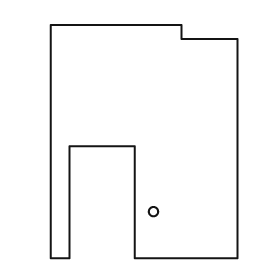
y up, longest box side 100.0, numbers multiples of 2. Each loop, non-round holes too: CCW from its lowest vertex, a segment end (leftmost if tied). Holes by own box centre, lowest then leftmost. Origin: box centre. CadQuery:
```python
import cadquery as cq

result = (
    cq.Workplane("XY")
    .moveTo(-40.0, -50.0)
    .lineTo(-32.0, -50.0)
    .lineTo(-32.0, -2.0)
    .lineTo(-4.0, -2.0)
    .lineTo(-4.0, -50.0)
    .lineTo(40.0, -50.0)
    .lineTo(40.0, 44.0)
    .lineTo(16.0, 44.0)
    .lineTo(16.0, 50.0)
    .lineTo(-40.0, 50.0)
    .close()
    .moveTo(4.0, -30.0)
    .circle(2.0)
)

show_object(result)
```